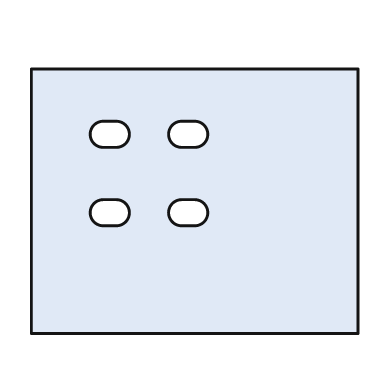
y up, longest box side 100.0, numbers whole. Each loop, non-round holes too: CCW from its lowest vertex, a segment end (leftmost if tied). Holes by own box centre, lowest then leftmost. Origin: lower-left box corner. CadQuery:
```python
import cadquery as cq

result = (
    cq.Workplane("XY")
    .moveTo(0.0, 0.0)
    .lineTo(100.0, 0.0)
    .lineTo(100.0, 81.0)
    .lineTo(0.0, 81.0)
    .close()
    .moveTo(22.0, 33.0)
    .lineTo(26.0, 33.0)
    .threePointArc((30.0, 37.0), (26.0, 41.0))
    .lineTo(22.0, 41.0)
    .threePointArc((18.0, 37.0), (22.0, 33.0))
    .close()
    .moveTo(46.0, 33.0)
    .lineTo(50.0, 33.0)
    .threePointArc((54.0, 37.0), (50.0, 41.0))
    .lineTo(46.0, 41.0)
    .threePointArc((42.0, 37.0), (46.0, 33.0))
    .close()
    .moveTo(22.0, 57.0)
    .lineTo(26.0, 57.0)
    .threePointArc((30.0, 61.0), (26.0, 65.0))
    .lineTo(22.0, 65.0)
    .threePointArc((18.0, 61.0), (22.0, 57.0))
    .close()
    .moveTo(46.0, 57.0)
    .lineTo(50.0, 57.0)
    .threePointArc((54.0, 61.0), (50.0, 65.0))
    .lineTo(46.0, 65.0)
    .threePointArc((42.0, 61.0), (46.0, 57.0))
    .close()
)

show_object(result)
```